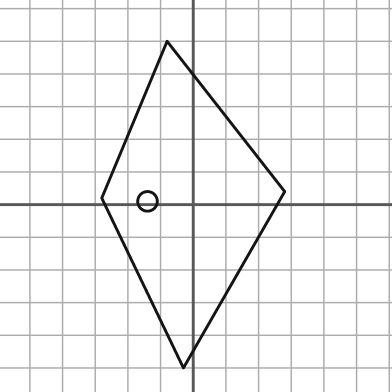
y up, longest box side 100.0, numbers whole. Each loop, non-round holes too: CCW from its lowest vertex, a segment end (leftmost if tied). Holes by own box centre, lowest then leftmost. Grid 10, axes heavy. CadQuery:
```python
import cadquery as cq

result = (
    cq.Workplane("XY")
    .moveTo(-3.0, -50.0)
    .lineTo(28.0, 4.0)
    .lineTo(-8.0, 50.0)
    .lineTo(-28.0, 2.0)
    .close()
    .moveTo(-14.0, 1.0)
    .circle(3.0)
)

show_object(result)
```